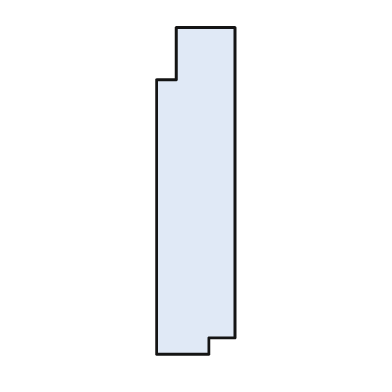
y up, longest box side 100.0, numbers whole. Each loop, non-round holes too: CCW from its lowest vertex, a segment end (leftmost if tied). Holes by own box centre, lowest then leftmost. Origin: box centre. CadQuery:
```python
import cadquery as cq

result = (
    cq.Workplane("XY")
    .moveTo(-12.0, -50.0)
    .lineTo(4.0, -50.0)
    .lineTo(4.0, -45.0)
    .lineTo(12.0, -45.0)
    .lineTo(12.0, 50.0)
    .lineTo(-6.0, 50.0)
    .lineTo(-6.0, 34.0)
    .lineTo(-12.0, 34.0)
    .close()
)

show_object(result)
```